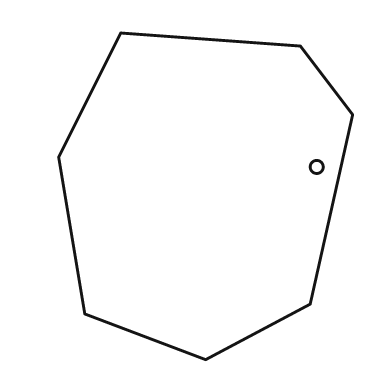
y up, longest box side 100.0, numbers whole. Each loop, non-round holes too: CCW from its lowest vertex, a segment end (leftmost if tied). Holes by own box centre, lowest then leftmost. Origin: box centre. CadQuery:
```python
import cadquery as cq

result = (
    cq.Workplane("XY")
    .moveTo(0.0, -50.0)
    .lineTo(32.0, -33.0)
    .lineTo(45.0, 25.0)
    .lineTo(29.0, 46.0)
    .lineTo(-26.0, 50.0)
    .lineTo(-45.0, 12.0)
    .lineTo(-37.0, -36.0)
    .close()
    .moveTo(34.0, 9.0)
    .circle(2.0)
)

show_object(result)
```